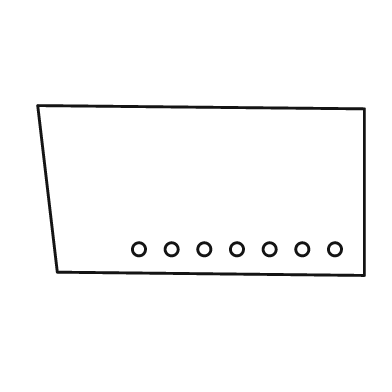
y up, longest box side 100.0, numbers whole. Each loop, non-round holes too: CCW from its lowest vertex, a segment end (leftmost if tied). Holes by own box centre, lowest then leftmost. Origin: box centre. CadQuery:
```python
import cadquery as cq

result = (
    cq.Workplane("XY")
    .moveTo(50.0, -26.0)
    .lineTo(50.0, 25.0)
    .lineTo(-50.0, 26.0)
    .lineTo(-44.0, -25.0)
    .close()
    .moveTo(-19.0, -18.0)
    .circle(2.0)
    .moveTo(-9.0, -18.0)
    .circle(2.0)
    .moveTo(1.0, -18.0)
    .circle(2.0)
    .moveTo(11.0, -18.0)
    .circle(2.0)
    .moveTo(21.0, -18.0)
    .circle(2.0)
    .moveTo(31.0, -18.0)
    .circle(2.0)
    .moveTo(41.0, -18.0)
    .circle(2.0)
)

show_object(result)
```